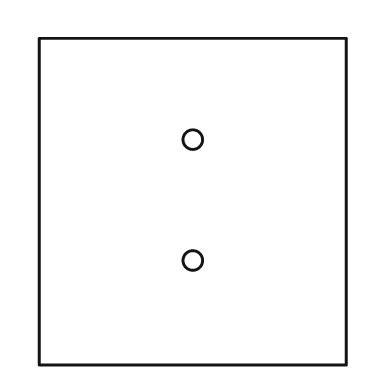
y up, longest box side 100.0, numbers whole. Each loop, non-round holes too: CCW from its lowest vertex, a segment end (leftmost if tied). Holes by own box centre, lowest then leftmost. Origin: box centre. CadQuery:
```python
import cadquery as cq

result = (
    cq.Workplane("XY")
    .moveTo(-47.0, -50.0)
    .lineTo(47.0, -50.0)
    .lineTo(47.0, 50.0)
    .lineTo(-47.0, 50.0)
    .close()
    .moveTo(0.0, -18.0)
    .circle(3.0)
    .moveTo(0.0, 19.0)
    .circle(3.0)
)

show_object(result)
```